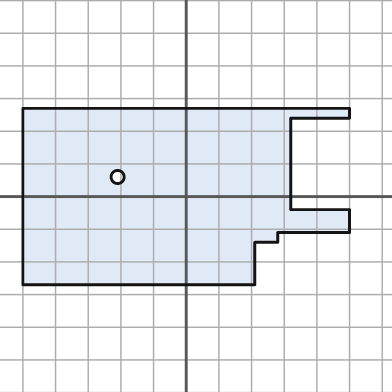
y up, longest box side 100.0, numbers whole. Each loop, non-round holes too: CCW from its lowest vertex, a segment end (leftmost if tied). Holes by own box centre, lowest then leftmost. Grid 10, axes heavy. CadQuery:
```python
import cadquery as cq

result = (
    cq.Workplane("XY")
    .moveTo(-50.0, -27.0)
    .lineTo(21.0, -27.0)
    .lineTo(21.0, -14.0)
    .lineTo(28.0, -14.0)
    .lineTo(28.0, -11.0)
    .lineTo(50.0, -11.0)
    .lineTo(50.0, -4.0)
    .lineTo(32.0, -4.0)
    .lineTo(32.0, 24.0)
    .lineTo(50.0, 24.0)
    .lineTo(50.0, 27.0)
    .lineTo(-50.0, 27.0)
    .close()
    .moveTo(-21.0, 6.0)
    .circle(2.0)
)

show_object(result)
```